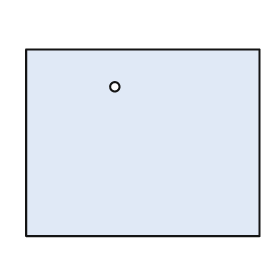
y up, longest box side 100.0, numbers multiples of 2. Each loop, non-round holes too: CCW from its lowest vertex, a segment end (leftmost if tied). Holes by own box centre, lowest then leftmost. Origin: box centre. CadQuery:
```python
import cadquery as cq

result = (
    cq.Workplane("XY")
    .moveTo(-50.0, -40.0)
    .lineTo(50.0, -40.0)
    .lineTo(50.0, 40.0)
    .lineTo(-50.0, 40.0)
    .close()
    .moveTo(-12.0, 24.0)
    .circle(2.0)
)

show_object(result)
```